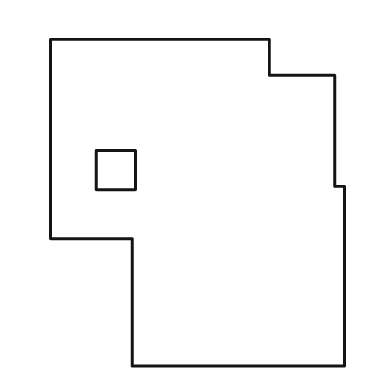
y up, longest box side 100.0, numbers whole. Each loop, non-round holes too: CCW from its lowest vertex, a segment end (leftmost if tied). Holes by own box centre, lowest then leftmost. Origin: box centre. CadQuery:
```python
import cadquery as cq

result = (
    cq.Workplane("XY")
    .moveTo(-20.0, -50.0)
    .lineTo(45.0, -50.0)
    .lineTo(45.0, 5.0)
    .lineTo(42.0, 5.0)
    .lineTo(42.0, 39.0)
    .lineTo(22.0, 39.0)
    .lineTo(22.0, 50.0)
    .lineTo(-45.0, 50.0)
    .lineTo(-45.0, -11.0)
    .lineTo(-20.0, -11.0)
    .close()
    .moveTo(-31.0, 4.0)
    .lineTo(-19.0, 4.0)
    .lineTo(-19.0, 16.0)
    .lineTo(-31.0, 16.0)
    .close()
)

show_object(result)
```